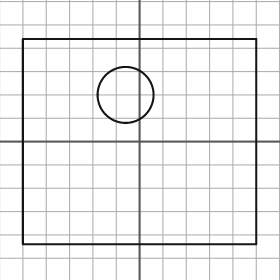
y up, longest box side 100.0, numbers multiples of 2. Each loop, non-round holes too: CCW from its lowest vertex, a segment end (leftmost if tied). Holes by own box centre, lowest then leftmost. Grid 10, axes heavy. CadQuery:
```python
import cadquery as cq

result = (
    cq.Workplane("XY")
    .moveTo(-50.0, -44.0)
    .lineTo(50.0, -44.0)
    .lineTo(50.0, 44.0)
    .lineTo(-50.0, 44.0)
    .close()
    .moveTo(-6.0, 20.0)
    .circle(12.0)
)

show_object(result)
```